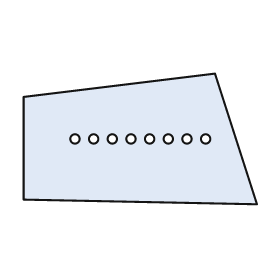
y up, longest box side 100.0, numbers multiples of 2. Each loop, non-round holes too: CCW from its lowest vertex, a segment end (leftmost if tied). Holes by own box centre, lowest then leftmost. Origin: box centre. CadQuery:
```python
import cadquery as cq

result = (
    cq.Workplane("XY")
    .moveTo(50.0, -28.0)
    .lineTo(32.0, 28.0)
    .lineTo(-50.0, 18.0)
    .lineTo(-50.0, -26.0)
    .close()
    .moveTo(-28.0, 0.0)
    .circle(2.0)
    .moveTo(-20.0, 0.0)
    .circle(2.0)
    .moveTo(-12.0, 0.0)
    .circle(2.0)
    .moveTo(-4.0, 0.0)
    .circle(2.0)
    .moveTo(4.0, 0.0)
    .circle(2.0)
    .moveTo(12.0, 0.0)
    .circle(2.0)
    .moveTo(20.0, 0.0)
    .circle(2.0)
    .moveTo(28.0, 0.0)
    .circle(2.0)
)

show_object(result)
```